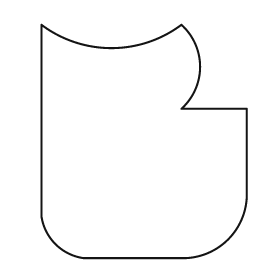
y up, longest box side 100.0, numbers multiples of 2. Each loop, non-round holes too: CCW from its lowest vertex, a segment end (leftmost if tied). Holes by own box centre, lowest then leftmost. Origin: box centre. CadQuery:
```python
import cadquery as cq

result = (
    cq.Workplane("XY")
    .moveTo(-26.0, -50.0)
    .lineTo(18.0, -50.0)
    .threePointArc((36.0, -42.0), (44.0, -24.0))
    .lineTo(44.0, 14.0)
    .lineTo(16.0, 14.0)
    .threePointArc((24.0, 32.0), (16.0, 50.0))
    .threePointArc((-14.0, 40.0), (-44.0, 50.0))
    .lineTo(-44.0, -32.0)
    .threePointArc((-38.0, -44.0), (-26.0, -50.0))
    .close()
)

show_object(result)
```